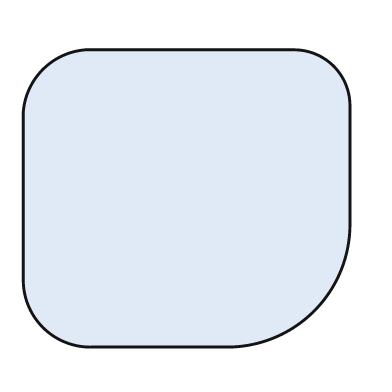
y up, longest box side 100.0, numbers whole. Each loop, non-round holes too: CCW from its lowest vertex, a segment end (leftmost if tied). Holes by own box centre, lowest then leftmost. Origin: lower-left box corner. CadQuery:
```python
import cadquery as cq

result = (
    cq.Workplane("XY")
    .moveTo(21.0, 0.0)
    .lineTo(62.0, 0.0)
    .threePointArc((89.0, 11.0), (100.0, 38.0))
    .lineTo(100.0, 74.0)
    .threePointArc((95.0, 86.0), (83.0, 91.0))
    .lineTo(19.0, 91.0)
    .threePointArc((6.0, 85.0), (0.0, 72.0))
    .lineTo(0.0, 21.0)
    .threePointArc((6.0, 6.0), (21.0, 0.0))
    .close()
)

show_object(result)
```